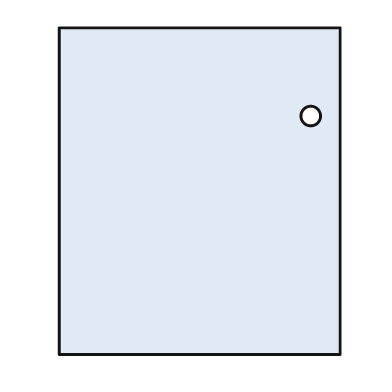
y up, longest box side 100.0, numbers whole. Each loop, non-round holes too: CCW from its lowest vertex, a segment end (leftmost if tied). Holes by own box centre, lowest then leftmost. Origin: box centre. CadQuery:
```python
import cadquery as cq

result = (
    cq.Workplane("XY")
    .moveTo(-43.0, -50.0)
    .lineTo(43.0, -50.0)
    .lineTo(43.0, 50.0)
    .lineTo(-43.0, 50.0)
    .close()
    .moveTo(34.0, 23.0)
    .circle(3.0)
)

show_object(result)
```